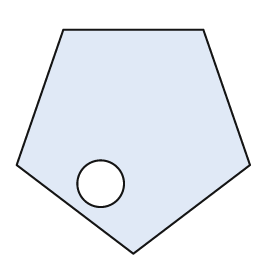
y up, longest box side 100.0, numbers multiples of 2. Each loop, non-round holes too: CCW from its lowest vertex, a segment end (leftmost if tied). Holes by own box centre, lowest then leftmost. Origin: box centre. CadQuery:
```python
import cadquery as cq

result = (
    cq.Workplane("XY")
    .moveTo(0.0, -48.0)
    .lineTo(50.0, -10.0)
    .lineTo(30.0, 48.0)
    .lineTo(-30.0, 48.0)
    .lineTo(-50.0, -10.0)
    .close()
    .moveTo(-14.0, -18.0)
    .circle(10.0)
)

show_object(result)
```